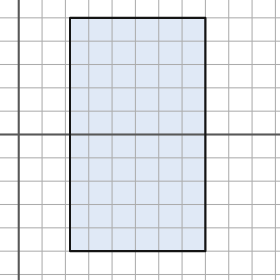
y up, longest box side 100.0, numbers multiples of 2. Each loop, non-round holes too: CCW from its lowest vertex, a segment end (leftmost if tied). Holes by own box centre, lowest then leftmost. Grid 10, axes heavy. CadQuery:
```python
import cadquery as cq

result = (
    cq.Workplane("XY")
    .moveTo(22.0, -50.0)
    .lineTo(80.0, -50.0)
    .lineTo(80.0, 50.0)
    .lineTo(22.0, 50.0)
    .close()
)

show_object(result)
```